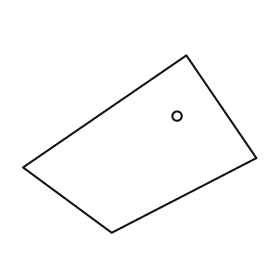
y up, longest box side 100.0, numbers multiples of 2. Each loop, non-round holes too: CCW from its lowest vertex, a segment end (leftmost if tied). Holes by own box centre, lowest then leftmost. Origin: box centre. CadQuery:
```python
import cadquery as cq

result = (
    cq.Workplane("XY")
    .moveTo(-12.0, -38.0)
    .lineTo(50.0, -6.0)
    .lineTo(20.0, 38.0)
    .lineTo(-50.0, -10.0)
    .close()
    .moveTo(16.0, 12.0)
    .circle(2.0)
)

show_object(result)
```